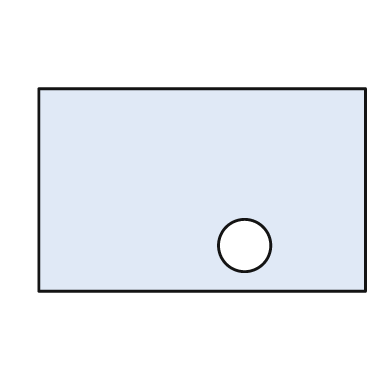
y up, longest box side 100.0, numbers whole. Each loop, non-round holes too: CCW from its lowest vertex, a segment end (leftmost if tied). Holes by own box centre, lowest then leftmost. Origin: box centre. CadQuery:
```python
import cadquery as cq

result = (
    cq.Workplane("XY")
    .moveTo(-50.0, -31.0)
    .lineTo(50.0, -31.0)
    .lineTo(50.0, 31.0)
    .lineTo(-50.0, 31.0)
    .close()
    .moveTo(13.0, -17.0)
    .circle(8.0)
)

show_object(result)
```